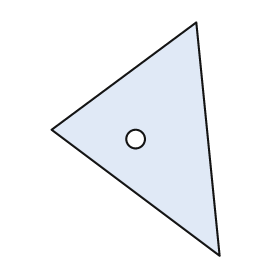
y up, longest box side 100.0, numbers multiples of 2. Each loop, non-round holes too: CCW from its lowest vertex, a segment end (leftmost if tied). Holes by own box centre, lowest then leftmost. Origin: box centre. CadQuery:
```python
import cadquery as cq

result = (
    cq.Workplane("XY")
    .moveTo(36.0, -50.0)
    .lineTo(26.0, 50.0)
    .lineTo(-36.0, 4.0)
    .close()
    .moveTo(0.0, 0.0)
    .circle(4.0)
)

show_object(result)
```